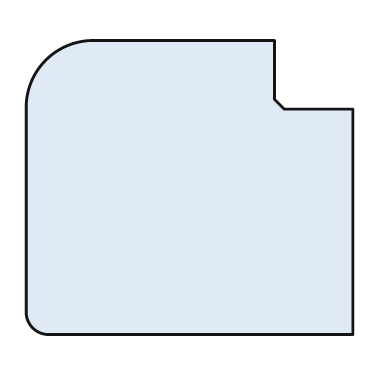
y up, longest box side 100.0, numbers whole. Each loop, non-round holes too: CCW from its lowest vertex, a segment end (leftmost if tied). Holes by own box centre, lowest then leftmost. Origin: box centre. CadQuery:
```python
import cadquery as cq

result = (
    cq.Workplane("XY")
    .moveTo(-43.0, -45.0)
    .lineTo(50.0, -45.0)
    .lineTo(50.0, 24.0)
    .lineTo(29.0, 24.0)
    .lineTo(26.0, 27.0)
    .lineTo(26.0, 45.0)
    .lineTo(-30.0, 45.0)
    .threePointArc((-44.0, 39.0), (-50.0, 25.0))
    .lineTo(-50.0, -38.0)
    .threePointArc((-48.0, -43.0), (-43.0, -45.0))
    .close()
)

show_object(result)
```